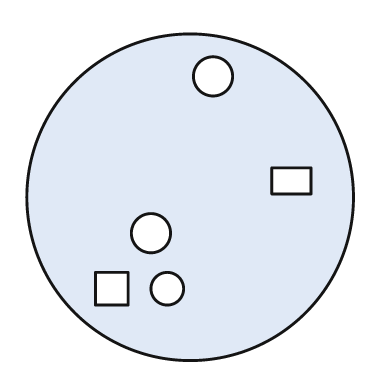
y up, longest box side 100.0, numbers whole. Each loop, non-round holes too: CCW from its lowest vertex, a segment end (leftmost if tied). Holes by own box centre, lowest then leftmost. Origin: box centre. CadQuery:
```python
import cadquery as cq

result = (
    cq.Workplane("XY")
    .moveTo(0.0, 0.0)
    .circle(50.0)
    .moveTo(-29.0, -33.0)
    .lineTo(-19.0, -33.0)
    .lineTo(-19.0, -23.0)
    .lineTo(-29.0, -23.0)
    .close()
    .moveTo(-7.0, -28.0)
    .circle(5.0)
    .moveTo(-12.0, -11.0)
    .circle(6.0)
    .moveTo(25.0, 1.0)
    .lineTo(37.0, 1.0)
    .lineTo(37.0, 9.0)
    .lineTo(25.0, 9.0)
    .close()
    .moveTo(7.0, 37.0)
    .circle(6.0)
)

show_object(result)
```